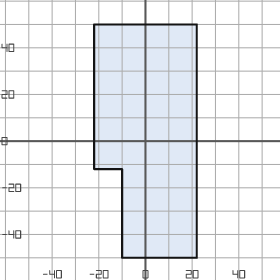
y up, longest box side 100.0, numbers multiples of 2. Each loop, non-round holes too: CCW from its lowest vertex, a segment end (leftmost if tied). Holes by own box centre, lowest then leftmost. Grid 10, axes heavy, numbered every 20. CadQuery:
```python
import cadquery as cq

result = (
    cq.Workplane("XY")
    .moveTo(-10.0, -50.0)
    .lineTo(22.0, -50.0)
    .lineTo(22.0, 50.0)
    .lineTo(-22.0, 50.0)
    .lineTo(-22.0, -12.0)
    .lineTo(-10.0, -12.0)
    .close()
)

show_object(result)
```